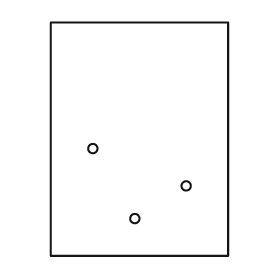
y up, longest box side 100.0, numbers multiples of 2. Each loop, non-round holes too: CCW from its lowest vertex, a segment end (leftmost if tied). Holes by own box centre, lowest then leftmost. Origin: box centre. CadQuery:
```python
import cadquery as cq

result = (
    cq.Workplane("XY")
    .moveTo(-38.0, -50.0)
    .lineTo(38.0, -50.0)
    .lineTo(38.0, 50.0)
    .lineTo(-38.0, 50.0)
    .close()
    .moveTo(-2.0, -34.0)
    .circle(2.0)
    .moveTo(20.0, -20.0)
    .circle(2.0)
    .moveTo(-20.0, -4.0)
    .circle(2.0)
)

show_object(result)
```